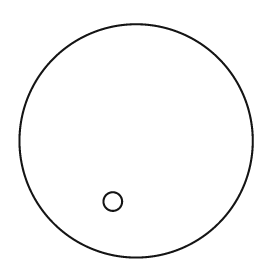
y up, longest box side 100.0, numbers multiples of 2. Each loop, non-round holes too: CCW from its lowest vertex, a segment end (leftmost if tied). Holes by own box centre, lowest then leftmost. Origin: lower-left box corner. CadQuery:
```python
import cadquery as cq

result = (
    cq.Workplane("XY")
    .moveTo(50.0, 50.0)
    .circle(50.0)
    .moveTo(40.0, 24.0)
    .circle(4.0)
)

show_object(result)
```